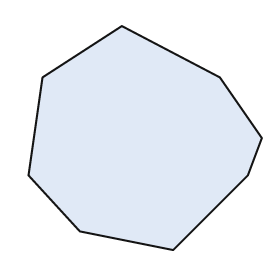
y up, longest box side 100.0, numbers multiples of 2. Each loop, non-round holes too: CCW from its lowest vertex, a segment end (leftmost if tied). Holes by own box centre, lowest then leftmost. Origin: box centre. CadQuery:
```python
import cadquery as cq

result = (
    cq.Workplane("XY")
    .moveTo(12.0, -48.0)
    .lineTo(44.0, -16.0)
    .lineTo(50.0, 0.0)
    .lineTo(32.0, 26.0)
    .lineTo(-10.0, 48.0)
    .lineTo(-44.0, 26.0)
    .lineTo(-50.0, -16.0)
    .lineTo(-28.0, -40.0)
    .close()
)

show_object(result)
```